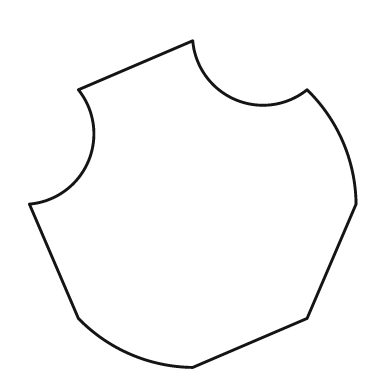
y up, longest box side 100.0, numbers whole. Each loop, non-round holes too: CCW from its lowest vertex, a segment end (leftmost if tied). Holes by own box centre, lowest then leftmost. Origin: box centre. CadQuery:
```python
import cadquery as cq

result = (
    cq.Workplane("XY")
    .moveTo(0.0, -50.0)
    .lineTo(35.0, -35.0)
    .lineTo(50.0, 0.0)
    .threePointArc((46.0, 19.0), (35.0, 35.0))
    .threePointArc((13.0, 32.0), (0.0, 50.0))
    .lineTo(-35.0, 35.0)
    .threePointArc((-32.0, 13.0), (-50.0, 0.0))
    .lineTo(-35.0, -35.0)
    .threePointArc((-19.0, -46.0), (0.0, -50.0))
    .close()
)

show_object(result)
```